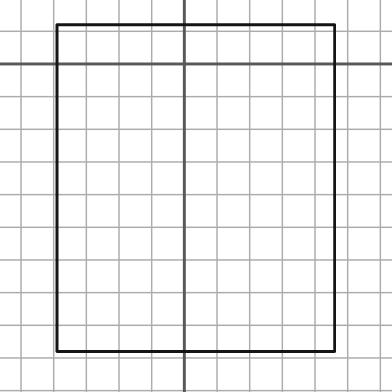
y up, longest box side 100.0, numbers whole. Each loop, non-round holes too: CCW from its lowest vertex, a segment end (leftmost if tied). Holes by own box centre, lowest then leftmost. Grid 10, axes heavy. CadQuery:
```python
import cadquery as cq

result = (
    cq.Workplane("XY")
    .moveTo(-39.0, -88.0)
    .lineTo(46.0, -88.0)
    .lineTo(46.0, 12.0)
    .lineTo(-39.0, 12.0)
    .close()
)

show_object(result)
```